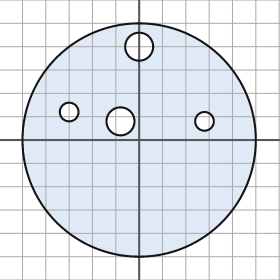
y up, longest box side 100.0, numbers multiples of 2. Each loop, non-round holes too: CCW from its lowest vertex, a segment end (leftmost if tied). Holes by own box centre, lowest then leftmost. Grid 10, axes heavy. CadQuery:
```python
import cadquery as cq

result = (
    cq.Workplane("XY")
    .moveTo(0.0, 0.0)
    .circle(50.0)
    .moveTo(-8.0, 8.0)
    .circle(6.0)
    .moveTo(28.0, 8.0)
    .circle(4.0)
    .moveTo(-30.0, 12.0)
    .circle(4.0)
    .moveTo(0.0, 40.0)
    .circle(6.0)
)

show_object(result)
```